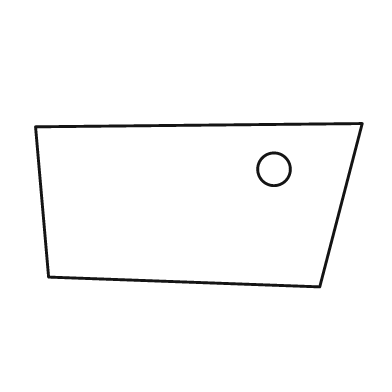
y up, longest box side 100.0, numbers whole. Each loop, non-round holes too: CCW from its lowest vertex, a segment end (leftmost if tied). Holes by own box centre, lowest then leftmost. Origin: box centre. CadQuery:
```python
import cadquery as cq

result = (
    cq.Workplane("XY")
    .moveTo(37.0, -25.0)
    .lineTo(50.0, 25.0)
    .lineTo(-50.0, 24.0)
    .lineTo(-46.0, -22.0)
    .close()
    .moveTo(23.0, 11.0)
    .circle(5.0)
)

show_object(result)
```